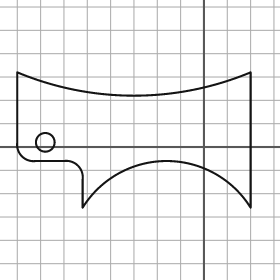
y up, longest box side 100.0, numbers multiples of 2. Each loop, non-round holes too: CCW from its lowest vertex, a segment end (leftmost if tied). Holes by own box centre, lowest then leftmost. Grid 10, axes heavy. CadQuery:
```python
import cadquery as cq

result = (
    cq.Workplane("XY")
    .moveTo(-52.0, -26.0)
    .threePointArc((-16.0, -6.0), (20.0, -26.0))
    .lineTo(20.0, 32.0)
    .threePointArc((-30.0, 22.0), (-80.0, 32.0))
    .lineTo(-80.0, 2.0)
    .threePointArc((-78.0, -4.0), (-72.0, -6.0))
    .lineTo(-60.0, -6.0)
    .threePointArc((-54.0, -8.0), (-52.0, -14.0))
    .close()
    .moveTo(-68.0, 2.0)
    .circle(4.0)
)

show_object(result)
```